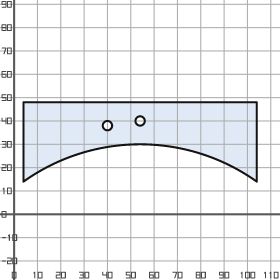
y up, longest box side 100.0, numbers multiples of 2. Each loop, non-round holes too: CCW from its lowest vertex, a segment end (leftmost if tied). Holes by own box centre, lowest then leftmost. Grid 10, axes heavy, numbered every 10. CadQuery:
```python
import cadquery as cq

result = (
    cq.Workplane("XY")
    .moveTo(4.0, 14.0)
    .threePointArc((54.0, 30.0), (104.0, 14.0))
    .lineTo(104.0, 48.0)
    .lineTo(4.0, 48.0)
    .close()
    .moveTo(40.0, 38.0)
    .circle(2.0)
    .moveTo(54.0, 40.0)
    .circle(2.0)
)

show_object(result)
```